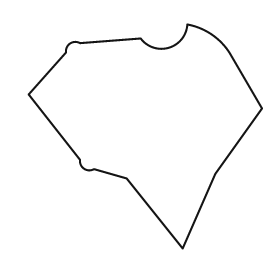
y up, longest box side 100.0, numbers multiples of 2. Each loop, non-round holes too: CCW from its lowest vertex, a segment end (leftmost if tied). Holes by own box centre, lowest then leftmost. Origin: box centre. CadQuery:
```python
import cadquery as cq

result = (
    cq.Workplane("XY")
    .moveTo(16.0, -48.0)
    .lineTo(30.0, -16.0)
    .lineTo(50.0, 12.0)
    .lineTo(36.0, 36.0)
    .threePointArc((28.0, 44.0), (18.0, 48.0))
    .threePointArc((10.0, 38.0), (-2.0, 42.0))
    .lineTo(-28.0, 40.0)
    .threePointArc((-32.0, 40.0), (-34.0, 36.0))
    .lineTo(-50.0, 18.0)
    .lineTo(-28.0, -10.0)
    .threePointArc((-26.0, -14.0), (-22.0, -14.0))
    .lineTo(-8.0, -18.0)
    .close()
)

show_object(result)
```